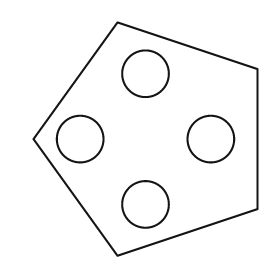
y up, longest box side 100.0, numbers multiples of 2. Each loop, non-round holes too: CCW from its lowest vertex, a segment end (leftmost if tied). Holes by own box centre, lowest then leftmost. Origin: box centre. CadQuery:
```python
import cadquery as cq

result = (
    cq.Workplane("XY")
    .moveTo(-12.0, -50.0)
    .lineTo(48.0, -30.0)
    .lineTo(48.0, 30.0)
    .lineTo(-12.0, 50.0)
    .lineTo(-48.0, 0.0)
    .close()
    .moveTo(0.0, -28.0)
    .circle(10.0)
    .moveTo(-28.0, 0.0)
    .circle(10.0)
    .moveTo(28.0, 0.0)
    .circle(10.0)
    .moveTo(0.0, 28.0)
    .circle(10.0)
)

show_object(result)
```